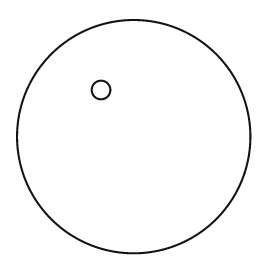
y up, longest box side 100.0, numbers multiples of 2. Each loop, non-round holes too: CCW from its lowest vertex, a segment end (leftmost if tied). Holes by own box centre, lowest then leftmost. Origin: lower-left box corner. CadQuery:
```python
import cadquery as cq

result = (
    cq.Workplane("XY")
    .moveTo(50.0, 50.0)
    .circle(50.0)
    .moveTo(36.0, 70.0)
    .circle(4.0)
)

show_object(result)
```